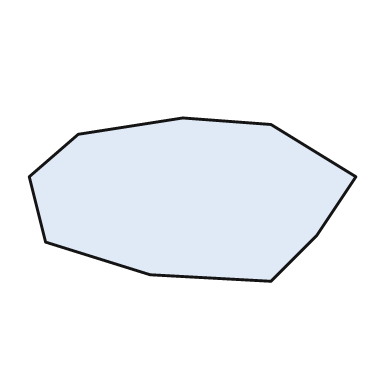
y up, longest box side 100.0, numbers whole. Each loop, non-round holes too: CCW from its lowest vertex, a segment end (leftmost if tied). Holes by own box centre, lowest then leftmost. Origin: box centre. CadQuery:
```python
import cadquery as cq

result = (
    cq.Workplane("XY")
    .moveTo(24.0, -25.0)
    .lineTo(38.0, -11.0)
    .lineTo(50.0, 7.0)
    .lineTo(24.0, 23.0)
    .lineTo(-3.0, 25.0)
    .lineTo(-35.0, 20.0)
    .lineTo(-50.0, 7.0)
    .lineTo(-45.0, -13.0)
    .lineTo(-13.0, -23.0)
    .close()
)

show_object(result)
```